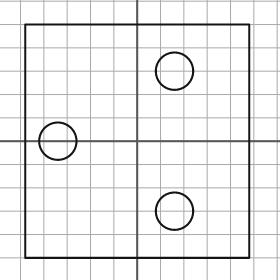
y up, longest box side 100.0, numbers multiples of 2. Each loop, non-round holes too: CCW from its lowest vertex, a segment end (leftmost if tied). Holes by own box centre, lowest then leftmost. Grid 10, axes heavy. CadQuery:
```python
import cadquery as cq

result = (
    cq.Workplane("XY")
    .moveTo(-48.0, -50.0)
    .lineTo(48.0, -50.0)
    .lineTo(48.0, 50.0)
    .lineTo(-48.0, 50.0)
    .close()
    .moveTo(16.0, -30.0)
    .circle(8.0)
    .moveTo(-34.0, 0.0)
    .circle(8.0)
    .moveTo(16.0, 30.0)
    .circle(8.0)
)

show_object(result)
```